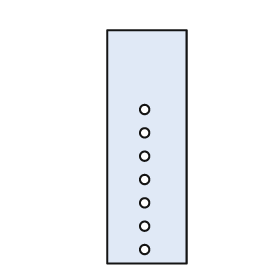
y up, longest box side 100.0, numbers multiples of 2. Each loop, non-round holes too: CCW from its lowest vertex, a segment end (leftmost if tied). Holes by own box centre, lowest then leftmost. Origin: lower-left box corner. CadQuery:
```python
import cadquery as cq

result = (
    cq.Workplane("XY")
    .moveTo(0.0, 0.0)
    .lineTo(34.0, 0.0)
    .lineTo(34.0, 100.0)
    .lineTo(0.0, 100.0)
    .close()
    .moveTo(16.0, 6.0)
    .circle(2.0)
    .moveTo(16.0, 16.0)
    .circle(2.0)
    .moveTo(16.0, 26.0)
    .circle(2.0)
    .moveTo(16.0, 36.0)
    .circle(2.0)
    .moveTo(16.0, 46.0)
    .circle(2.0)
    .moveTo(16.0, 56.0)
    .circle(2.0)
    .moveTo(16.0, 66.0)
    .circle(2.0)
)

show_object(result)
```